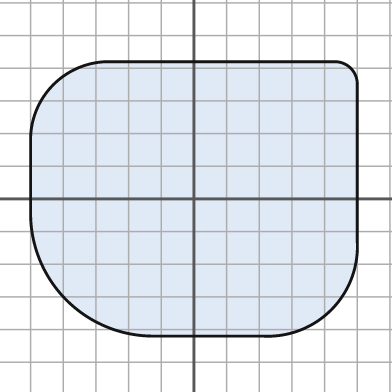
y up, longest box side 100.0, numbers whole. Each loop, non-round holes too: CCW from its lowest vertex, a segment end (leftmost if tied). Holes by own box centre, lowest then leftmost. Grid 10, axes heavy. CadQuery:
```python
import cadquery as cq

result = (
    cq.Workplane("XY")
    .moveTo(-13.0, -42.0)
    .lineTo(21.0, -42.0)
    .threePointArc((42.0, -34.0), (50.0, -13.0))
    .lineTo(50.0, 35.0)
    .threePointArc((48.0, 40.0), (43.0, 42.0))
    .lineTo(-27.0, 42.0)
    .threePointArc((-43.0, 35.0), (-50.0, 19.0))
    .lineTo(-50.0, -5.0)
    .threePointArc((-39.0, -31.0), (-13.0, -42.0))
    .close()
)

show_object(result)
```